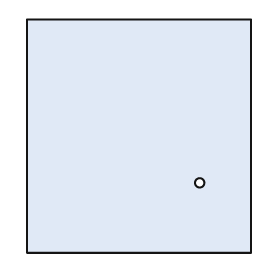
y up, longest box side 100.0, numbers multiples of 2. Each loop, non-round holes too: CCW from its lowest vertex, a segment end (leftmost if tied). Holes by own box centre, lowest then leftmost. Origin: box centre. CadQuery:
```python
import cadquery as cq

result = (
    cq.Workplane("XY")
    .moveTo(-48.0, -50.0)
    .lineTo(48.0, -50.0)
    .lineTo(48.0, 50.0)
    .lineTo(-48.0, 50.0)
    .close()
    .moveTo(26.0, -20.0)
    .circle(2.0)
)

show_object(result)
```